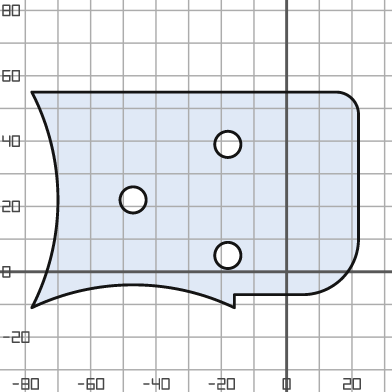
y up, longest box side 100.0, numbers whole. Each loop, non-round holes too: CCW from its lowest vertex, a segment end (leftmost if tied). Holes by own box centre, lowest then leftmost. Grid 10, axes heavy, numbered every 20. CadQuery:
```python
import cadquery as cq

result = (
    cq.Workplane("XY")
    .moveTo(-78.0, -11.0)
    .threePointArc((-47.0, -4.0), (-16.0, -11.0))
    .lineTo(-16.0, -7.0)
    .lineTo(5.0, -7.0)
    .threePointArc((17.0, -2.0), (22.0, 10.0))
    .lineTo(22.0, 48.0)
    .threePointArc((20.0, 53.0), (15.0, 55.0))
    .lineTo(-78.0, 55.0)
    .threePointArc((-70.0, 22.0), (-78.0, -11.0))
    .close()
    .moveTo(-18.0, 5.0)
    .circle(4.0)
    .moveTo(-47.0, 22.0)
    .circle(4.0)
    .moveTo(-18.0, 39.0)
    .circle(4.0)
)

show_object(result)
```